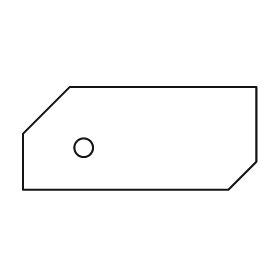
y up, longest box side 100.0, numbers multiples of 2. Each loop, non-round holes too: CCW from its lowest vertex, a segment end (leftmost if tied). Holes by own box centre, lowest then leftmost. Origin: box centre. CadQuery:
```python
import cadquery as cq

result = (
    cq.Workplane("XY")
    .moveTo(-50.0, -22.0)
    .lineTo(38.0, -22.0)
    .lineTo(50.0, -10.0)
    .lineTo(50.0, 22.0)
    .lineTo(-30.0, 22.0)
    .lineTo(-50.0, 2.0)
    .close()
    .moveTo(-24.0, -4.0)
    .circle(4.0)
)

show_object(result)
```